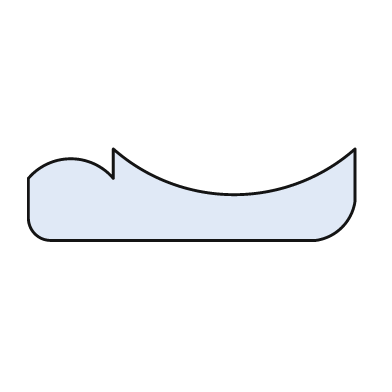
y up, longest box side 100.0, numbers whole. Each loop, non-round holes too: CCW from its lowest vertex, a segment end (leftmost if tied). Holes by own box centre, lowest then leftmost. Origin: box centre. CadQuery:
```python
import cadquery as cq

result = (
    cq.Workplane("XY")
    .moveTo(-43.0, -14.0)
    .lineTo(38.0, -14.0)
    .threePointArc((46.0, -10.0), (50.0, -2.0))
    .lineTo(50.0, 14.0)
    .threePointArc((13.0, 0.0), (-24.0, 14.0))
    .lineTo(-24.0, 5.0)
    .threePointArc((-37.0, 11.0), (-50.0, 5.0))
    .lineTo(-50.0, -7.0)
    .threePointArc((-48.0, -12.0), (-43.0, -14.0))
    .close()
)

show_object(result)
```